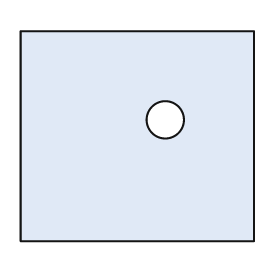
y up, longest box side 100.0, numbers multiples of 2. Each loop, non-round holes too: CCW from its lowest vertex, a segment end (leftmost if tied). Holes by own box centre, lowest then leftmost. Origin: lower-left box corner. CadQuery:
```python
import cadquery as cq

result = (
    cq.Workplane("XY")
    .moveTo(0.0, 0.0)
    .lineTo(100.0, 0.0)
    .lineTo(100.0, 90.0)
    .lineTo(0.0, 90.0)
    .close()
    .moveTo(62.0, 52.0)
    .circle(8.0)
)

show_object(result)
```